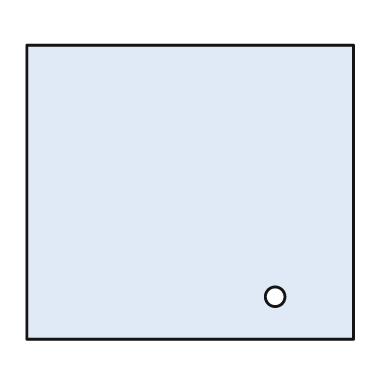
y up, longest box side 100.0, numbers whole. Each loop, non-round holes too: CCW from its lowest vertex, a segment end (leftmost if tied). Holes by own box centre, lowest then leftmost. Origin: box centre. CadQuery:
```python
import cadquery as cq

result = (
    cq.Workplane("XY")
    .moveTo(-50.0, -45.0)
    .lineTo(50.0, -45.0)
    .lineTo(50.0, 45.0)
    .lineTo(-50.0, 45.0)
    .close()
    .moveTo(26.0, -32.0)
    .circle(3.0)
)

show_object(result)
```